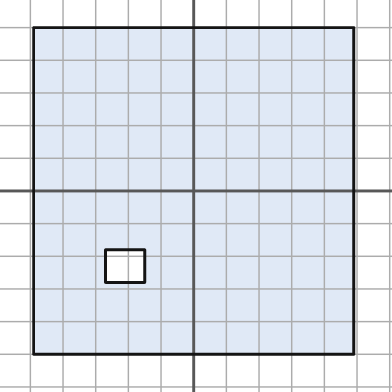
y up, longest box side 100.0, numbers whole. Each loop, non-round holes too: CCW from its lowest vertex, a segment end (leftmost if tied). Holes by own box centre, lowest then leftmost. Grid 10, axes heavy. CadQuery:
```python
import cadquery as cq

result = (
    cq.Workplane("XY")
    .moveTo(-49.0, -50.0)
    .lineTo(49.0, -50.0)
    .lineTo(49.0, 50.0)
    .lineTo(-49.0, 50.0)
    .close()
    .moveTo(-27.0, -28.0)
    .lineTo(-15.0, -28.0)
    .lineTo(-15.0, -18.0)
    .lineTo(-27.0, -18.0)
    .close()
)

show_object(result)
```